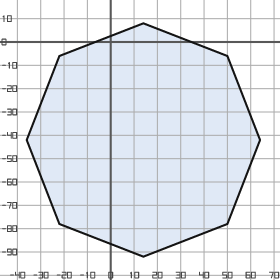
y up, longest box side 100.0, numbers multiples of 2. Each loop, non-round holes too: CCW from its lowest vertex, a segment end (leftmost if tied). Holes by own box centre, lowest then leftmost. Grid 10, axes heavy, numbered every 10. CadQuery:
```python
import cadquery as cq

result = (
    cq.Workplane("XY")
    .moveTo(14.0, -92.0)
    .lineTo(50.0, -78.0)
    .lineTo(64.0, -42.0)
    .lineTo(50.0, -6.0)
    .lineTo(14.0, 8.0)
    .lineTo(-22.0, -6.0)
    .lineTo(-36.0, -42.0)
    .lineTo(-22.0, -78.0)
    .close()
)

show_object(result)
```